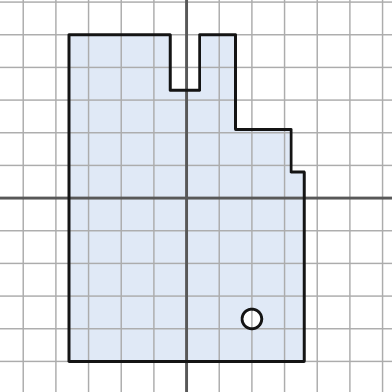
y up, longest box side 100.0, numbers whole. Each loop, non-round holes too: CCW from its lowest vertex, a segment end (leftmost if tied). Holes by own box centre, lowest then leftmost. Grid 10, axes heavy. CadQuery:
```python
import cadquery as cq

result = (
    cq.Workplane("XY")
    .moveTo(-36.0, -50.0)
    .lineTo(36.0, -50.0)
    .lineTo(36.0, 8.0)
    .lineTo(32.0, 8.0)
    .lineTo(32.0, 21.0)
    .lineTo(15.0, 21.0)
    .lineTo(15.0, 50.0)
    .lineTo(4.0, 50.0)
    .lineTo(4.0, 33.0)
    .lineTo(-5.0, 33.0)
    .lineTo(-5.0, 50.0)
    .lineTo(-36.0, 50.0)
    .close()
    .moveTo(20.0, -37.0)
    .circle(3.0)
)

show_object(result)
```